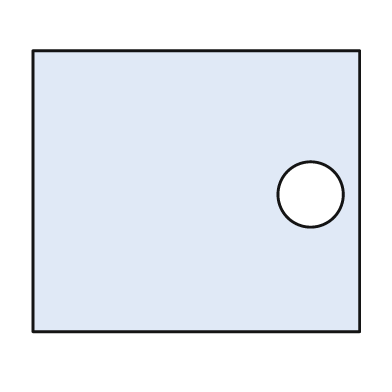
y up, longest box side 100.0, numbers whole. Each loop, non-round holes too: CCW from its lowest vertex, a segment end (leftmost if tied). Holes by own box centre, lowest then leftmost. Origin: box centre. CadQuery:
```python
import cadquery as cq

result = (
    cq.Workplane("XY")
    .moveTo(-50.0, -43.0)
    .lineTo(50.0, -43.0)
    .lineTo(50.0, 43.0)
    .lineTo(-50.0, 43.0)
    .close()
    .moveTo(35.0, -1.0)
    .circle(10.0)
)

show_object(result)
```